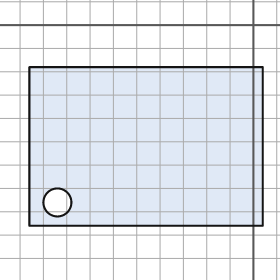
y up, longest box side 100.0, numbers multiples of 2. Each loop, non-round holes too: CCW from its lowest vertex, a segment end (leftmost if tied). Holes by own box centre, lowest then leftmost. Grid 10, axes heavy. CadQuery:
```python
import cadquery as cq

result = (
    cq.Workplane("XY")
    .moveTo(-96.0, -86.0)
    .lineTo(4.0, -86.0)
    .lineTo(4.0, -18.0)
    .lineTo(-96.0, -18.0)
    .close()
    .moveTo(-84.0, -76.0)
    .circle(6.0)
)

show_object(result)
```